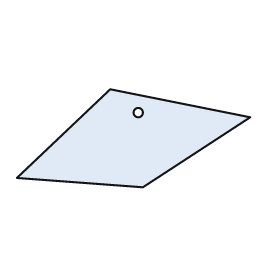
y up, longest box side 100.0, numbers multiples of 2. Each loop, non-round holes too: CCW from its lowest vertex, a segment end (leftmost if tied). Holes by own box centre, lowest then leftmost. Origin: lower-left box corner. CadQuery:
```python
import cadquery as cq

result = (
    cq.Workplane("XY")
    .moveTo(54.0, 0.0)
    .lineTo(100.0, 30.0)
    .lineTo(40.0, 42.0)
    .lineTo(0.0, 4.0)
    .close()
    .moveTo(52.0, 32.0)
    .circle(2.0)
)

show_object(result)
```